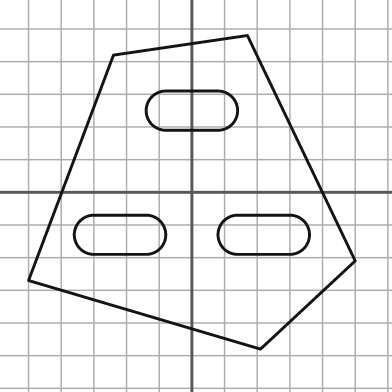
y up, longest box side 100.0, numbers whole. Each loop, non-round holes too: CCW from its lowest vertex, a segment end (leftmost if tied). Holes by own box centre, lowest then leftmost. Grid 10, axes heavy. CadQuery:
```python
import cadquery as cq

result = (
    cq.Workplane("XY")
    .moveTo(21.0, -48.0)
    .lineTo(50.0, -21.0)
    .lineTo(17.0, 48.0)
    .lineTo(-24.0, 42.0)
    .lineTo(-50.0, -27.0)
    .close()
    .moveTo(-30.0, -19.0)
    .lineTo(-14.0, -19.0)
    .threePointArc((-8.0, -13.0), (-14.0, -7.0))
    .lineTo(-30.0, -7.0)
    .threePointArc((-36.0, -13.0), (-30.0, -19.0))
    .close()
    .moveTo(14.0, -19.0)
    .lineTo(30.0, -19.0)
    .threePointArc((36.0, -13.0), (30.0, -7.0))
    .lineTo(14.0, -7.0)
    .threePointArc((8.0, -13.0), (14.0, -19.0))
    .close()
    .moveTo(-8.0, 19.0)
    .lineTo(8.0, 19.0)
    .threePointArc((14.0, 25.0), (8.0, 31.0))
    .lineTo(-8.0, 31.0)
    .threePointArc((-14.0, 25.0), (-8.0, 19.0))
    .close()
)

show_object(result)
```